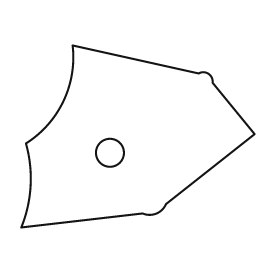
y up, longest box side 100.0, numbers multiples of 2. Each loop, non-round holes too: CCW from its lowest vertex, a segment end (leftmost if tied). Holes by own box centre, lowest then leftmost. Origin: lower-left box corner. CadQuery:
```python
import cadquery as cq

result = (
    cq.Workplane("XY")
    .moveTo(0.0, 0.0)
    .lineTo(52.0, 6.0)
    .threePointArc((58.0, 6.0), (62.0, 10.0))
    .lineTo(100.0, 40.0)
    .lineTo(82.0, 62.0)
    .threePointArc((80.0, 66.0), (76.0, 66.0))
    .lineTo(22.0, 78.0)
    .threePointArc((18.0, 54.0), (2.0, 36.0))
    .threePointArc((4.0, 18.0), (0.0, 0.0))
    .close()
    .moveTo(38.0, 32.0)
    .circle(6.0)
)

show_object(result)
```